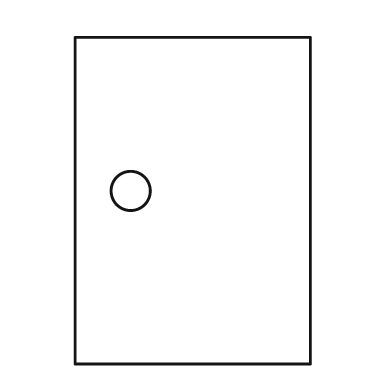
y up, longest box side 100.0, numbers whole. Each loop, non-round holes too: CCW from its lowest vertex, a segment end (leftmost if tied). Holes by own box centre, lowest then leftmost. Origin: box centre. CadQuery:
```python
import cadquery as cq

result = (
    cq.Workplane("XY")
    .moveTo(-36.0, -50.0)
    .lineTo(36.0, -50.0)
    .lineTo(36.0, 50.0)
    .lineTo(-36.0, 50.0)
    .close()
    .moveTo(-19.0, 3.0)
    .circle(6.0)
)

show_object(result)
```